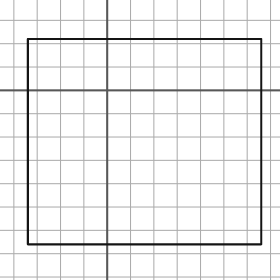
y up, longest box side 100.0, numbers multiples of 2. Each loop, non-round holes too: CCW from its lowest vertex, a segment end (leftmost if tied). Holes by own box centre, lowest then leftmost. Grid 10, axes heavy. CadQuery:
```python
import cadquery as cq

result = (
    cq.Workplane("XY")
    .moveTo(-34.0, -66.0)
    .lineTo(66.0, -66.0)
    .lineTo(66.0, 22.0)
    .lineTo(-34.0, 22.0)
    .close()
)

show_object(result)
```